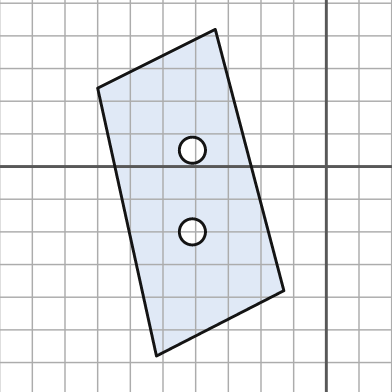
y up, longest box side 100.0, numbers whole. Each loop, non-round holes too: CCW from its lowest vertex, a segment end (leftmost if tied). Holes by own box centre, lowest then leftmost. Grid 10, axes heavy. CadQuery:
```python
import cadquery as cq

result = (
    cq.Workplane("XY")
    .moveTo(-52.0, -58.0)
    .lineTo(-13.0, -38.0)
    .lineTo(-34.0, 42.0)
    .lineTo(-70.0, 24.0)
    .close()
    .moveTo(-41.0, -20.0)
    .circle(4.0)
    .moveTo(-41.0, 5.0)
    .circle(4.0)
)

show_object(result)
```